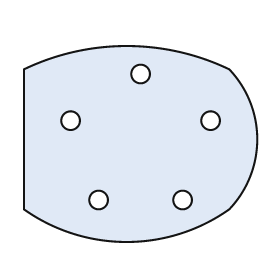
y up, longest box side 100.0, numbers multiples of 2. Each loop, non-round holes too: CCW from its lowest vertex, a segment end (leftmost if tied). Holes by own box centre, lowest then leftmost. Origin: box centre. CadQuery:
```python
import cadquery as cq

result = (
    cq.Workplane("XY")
    .moveTo(-50.0, -28.0)
    .threePointArc((-6.0, -42.0), (38.0, -28.0))
    .threePointArc((50.0, 2.0), (38.0, 32.0))
    .threePointArc((-6.0, 42.0), (-50.0, 32.0))
    .close()
    .moveTo(-18.0, -24.0)
    .circle(4.0)
    .moveTo(18.0, -24.0)
    .circle(4.0)
    .moveTo(-30.0, 10.0)
    .circle(4.0)
    .moveTo(30.0, 10.0)
    .circle(4.0)
    .moveTo(0.0, 30.0)
    .circle(4.0)
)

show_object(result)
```